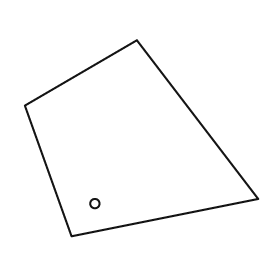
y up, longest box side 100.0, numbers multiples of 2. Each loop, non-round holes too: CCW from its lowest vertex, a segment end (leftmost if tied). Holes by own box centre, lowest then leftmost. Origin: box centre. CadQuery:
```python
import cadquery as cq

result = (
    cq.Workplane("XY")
    .moveTo(-30.0, -42.0)
    .lineTo(50.0, -26.0)
    .lineTo(-2.0, 42.0)
    .lineTo(-50.0, 14.0)
    .close()
    .moveTo(-20.0, -28.0)
    .circle(2.0)
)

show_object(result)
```